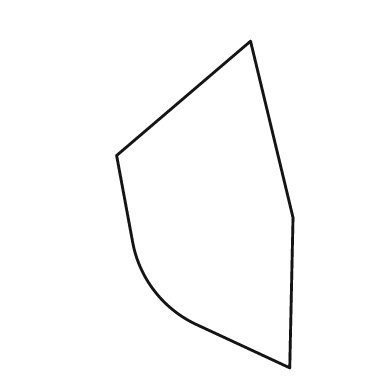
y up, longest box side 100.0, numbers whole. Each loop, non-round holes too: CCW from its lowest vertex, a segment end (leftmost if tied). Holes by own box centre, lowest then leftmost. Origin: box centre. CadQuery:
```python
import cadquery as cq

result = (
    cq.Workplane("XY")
    .moveTo(26.0, -50.0)
    .lineTo(27.0, -4.0)
    .lineTo(14.0, 50.0)
    .lineTo(-27.0, 15.0)
    .lineTo(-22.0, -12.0)
    .threePointArc((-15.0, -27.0), (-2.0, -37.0))
    .close()
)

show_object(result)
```